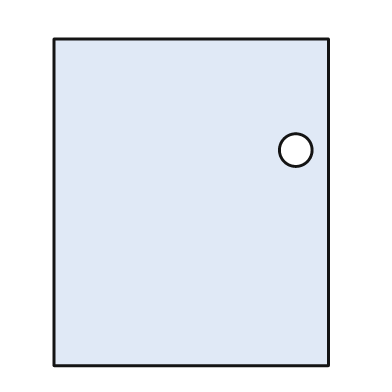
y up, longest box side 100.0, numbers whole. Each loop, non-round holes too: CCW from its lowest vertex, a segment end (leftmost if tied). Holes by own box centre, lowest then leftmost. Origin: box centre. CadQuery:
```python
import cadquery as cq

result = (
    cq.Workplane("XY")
    .moveTo(-42.0, -50.0)
    .lineTo(42.0, -50.0)
    .lineTo(42.0, 50.0)
    .lineTo(-42.0, 50.0)
    .close()
    .moveTo(32.0, 16.0)
    .circle(5.0)
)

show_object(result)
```